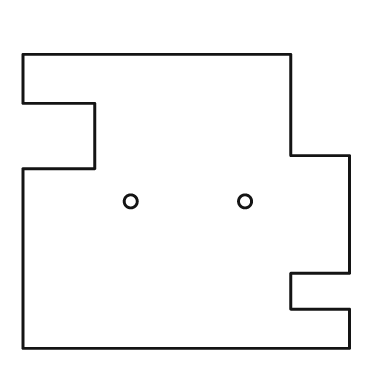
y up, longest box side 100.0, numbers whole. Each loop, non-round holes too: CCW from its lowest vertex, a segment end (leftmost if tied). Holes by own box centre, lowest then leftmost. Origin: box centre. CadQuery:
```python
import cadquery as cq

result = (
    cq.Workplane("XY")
    .moveTo(-50.0, -45.0)
    .lineTo(50.0, -45.0)
    .lineTo(50.0, -33.0)
    .lineTo(32.0, -33.0)
    .lineTo(32.0, -22.0)
    .lineTo(50.0, -22.0)
    .lineTo(50.0, 14.0)
    .lineTo(32.0, 14.0)
    .lineTo(32.0, 45.0)
    .lineTo(-50.0, 45.0)
    .lineTo(-50.0, 30.0)
    .lineTo(-28.0, 30.0)
    .lineTo(-28.0, 10.0)
    .lineTo(-50.0, 10.0)
    .close()
    .moveTo(-17.0, 0.0)
    .circle(2.0)
    .moveTo(18.0, 0.0)
    .circle(2.0)
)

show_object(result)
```